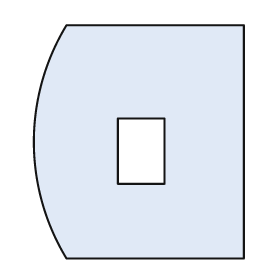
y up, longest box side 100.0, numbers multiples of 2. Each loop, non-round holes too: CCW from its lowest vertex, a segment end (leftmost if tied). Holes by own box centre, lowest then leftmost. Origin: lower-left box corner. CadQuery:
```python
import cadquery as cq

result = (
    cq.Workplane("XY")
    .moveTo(14.0, 0.0)
    .lineTo(90.0, 0.0)
    .lineTo(90.0, 100.0)
    .lineTo(14.0, 100.0)
    .threePointArc((0.0, 50.0), (14.0, 0.0))
    .close()
    .moveTo(36.0, 32.0)
    .lineTo(56.0, 32.0)
    .lineTo(56.0, 60.0)
    .lineTo(36.0, 60.0)
    .close()
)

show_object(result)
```